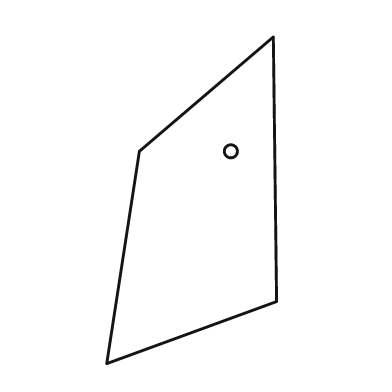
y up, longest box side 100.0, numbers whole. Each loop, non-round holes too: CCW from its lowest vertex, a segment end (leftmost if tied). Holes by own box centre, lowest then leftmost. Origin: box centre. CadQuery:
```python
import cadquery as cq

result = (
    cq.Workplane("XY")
    .moveTo(-26.0, -50.0)
    .lineTo(26.0, -31.0)
    .lineTo(25.0, 50.0)
    .lineTo(-16.0, 15.0)
    .close()
    .moveTo(12.0, 15.0)
    .circle(2.0)
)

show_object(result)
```